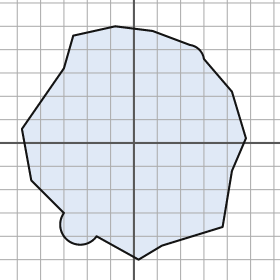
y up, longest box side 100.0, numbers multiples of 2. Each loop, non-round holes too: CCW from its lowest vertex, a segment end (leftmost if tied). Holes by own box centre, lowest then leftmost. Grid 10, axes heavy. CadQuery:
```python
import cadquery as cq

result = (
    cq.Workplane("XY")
    .moveTo(2.0, -50.0)
    .lineTo(12.0, -44.0)
    .lineTo(38.0, -36.0)
    .lineTo(42.0, -12.0)
    .lineTo(48.0, 2.0)
    .lineTo(42.0, 22.0)
    .lineTo(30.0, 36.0)
    .threePointArc((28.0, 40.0), (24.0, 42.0))
    .lineTo(8.0, 48.0)
    .lineTo(-8.0, 50.0)
    .lineTo(-26.0, 46.0)
    .lineTo(-30.0, 32.0)
    .lineTo(-48.0, 6.0)
    .lineTo(-44.0, -16.0)
    .lineTo(-30.0, -30.0)
    .threePointArc((-28.0, -42.0), (-16.0, -40.0))
    .close()
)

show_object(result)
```